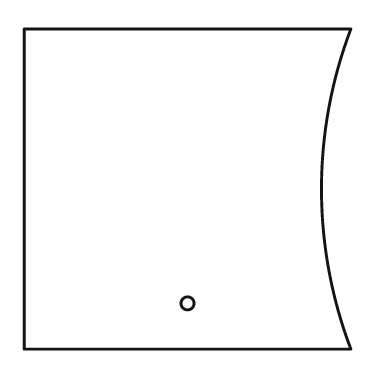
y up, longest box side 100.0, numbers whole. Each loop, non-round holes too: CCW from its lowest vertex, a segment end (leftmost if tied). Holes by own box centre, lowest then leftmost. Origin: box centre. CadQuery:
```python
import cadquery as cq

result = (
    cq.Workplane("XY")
    .moveTo(-50.0, -49.0)
    .lineTo(50.0, -49.0)
    .threePointArc((41.0, 0.0), (50.0, 49.0))
    .lineTo(-50.0, 49.0)
    .close()
    .moveTo(0.0, -35.0)
    .circle(2.0)
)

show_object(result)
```